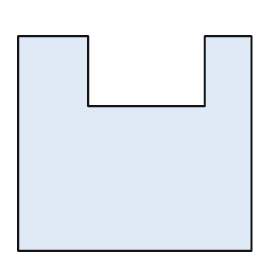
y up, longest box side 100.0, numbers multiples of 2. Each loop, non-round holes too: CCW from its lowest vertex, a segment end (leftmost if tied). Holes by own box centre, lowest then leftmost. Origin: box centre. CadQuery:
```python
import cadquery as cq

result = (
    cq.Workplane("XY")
    .moveTo(-50.0, -46.0)
    .lineTo(50.0, -46.0)
    .lineTo(50.0, 46.0)
    .lineTo(30.0, 46.0)
    .lineTo(30.0, 16.0)
    .lineTo(-20.0, 16.0)
    .lineTo(-20.0, 46.0)
    .lineTo(-50.0, 46.0)
    .close()
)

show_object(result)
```